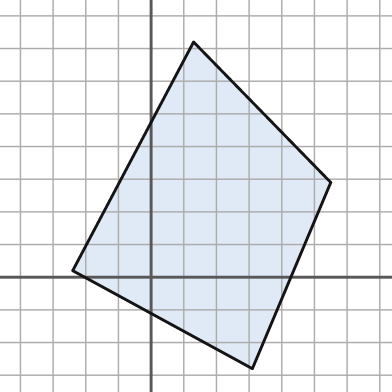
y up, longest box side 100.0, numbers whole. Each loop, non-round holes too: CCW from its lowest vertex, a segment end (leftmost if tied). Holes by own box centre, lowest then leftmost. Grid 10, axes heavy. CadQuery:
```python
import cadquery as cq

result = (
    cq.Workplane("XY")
    .moveTo(31.0, -28.0)
    .lineTo(55.0, 29.0)
    .lineTo(13.0, 72.0)
    .lineTo(-24.0, 2.0)
    .close()
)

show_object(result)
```